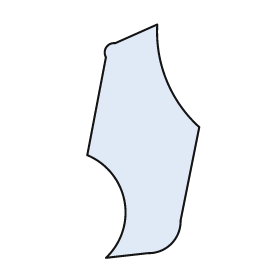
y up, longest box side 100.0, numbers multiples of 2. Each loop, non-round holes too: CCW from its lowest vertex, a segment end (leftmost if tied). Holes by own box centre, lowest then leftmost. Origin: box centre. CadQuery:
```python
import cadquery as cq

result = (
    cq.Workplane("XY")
    .moveTo(-16.0, -50.0)
    .lineTo(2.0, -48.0)
    .threePointArc((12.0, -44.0), (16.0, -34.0))
    .lineTo(24.0, 6.0)
    .threePointArc((10.0, 26.0), (6.0, 50.0))
    .lineTo(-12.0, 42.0)
    .threePointArc((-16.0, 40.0), (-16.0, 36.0))
    .lineTo(-24.0, -6.0)
    .threePointArc((-8.0, -26.0), (-16.0, -50.0))
    .close()
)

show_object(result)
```